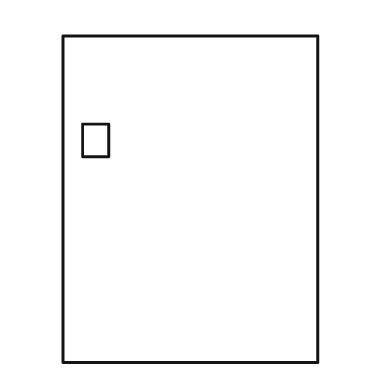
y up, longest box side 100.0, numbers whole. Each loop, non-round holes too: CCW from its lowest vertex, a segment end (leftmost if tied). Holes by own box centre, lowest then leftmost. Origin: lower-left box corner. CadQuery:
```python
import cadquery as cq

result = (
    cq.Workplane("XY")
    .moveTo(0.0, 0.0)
    .lineTo(78.0, 0.0)
    .lineTo(78.0, 100.0)
    .lineTo(0.0, 100.0)
    .close()
    .moveTo(6.0, 63.0)
    .lineTo(14.0, 63.0)
    .lineTo(14.0, 73.0)
    .lineTo(6.0, 73.0)
    .close()
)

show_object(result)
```